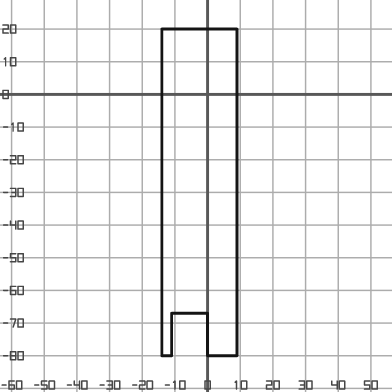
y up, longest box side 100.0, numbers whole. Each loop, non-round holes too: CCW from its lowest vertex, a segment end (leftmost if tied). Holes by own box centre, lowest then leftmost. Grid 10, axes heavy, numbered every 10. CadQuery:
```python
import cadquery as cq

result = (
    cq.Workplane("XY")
    .moveTo(-14.0, -80.0)
    .lineTo(-11.0, -80.0)
    .lineTo(-11.0, -67.0)
    .lineTo(0.0, -67.0)
    .lineTo(0.0, -80.0)
    .lineTo(9.0, -80.0)
    .lineTo(9.0, 20.0)
    .lineTo(-14.0, 20.0)
    .close()
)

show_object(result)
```